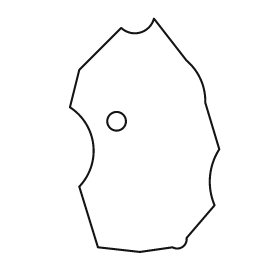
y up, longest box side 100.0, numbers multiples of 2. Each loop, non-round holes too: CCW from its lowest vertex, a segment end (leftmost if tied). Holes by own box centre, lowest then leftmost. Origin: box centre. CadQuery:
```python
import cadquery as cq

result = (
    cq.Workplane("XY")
    .moveTo(-2.0, -50.0)
    .lineTo(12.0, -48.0)
    .threePointArc((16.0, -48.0), (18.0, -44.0))
    .lineTo(30.0, -30.0)
    .threePointArc((28.0, -18.0), (32.0, -6.0))
    .lineTo(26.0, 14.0)
    .threePointArc((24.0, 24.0), (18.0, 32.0))
    .lineTo(4.0, 50.0)
    .threePointArc((-2.0, 44.0), (-10.0, 46.0))
    .lineTo(-28.0, 28.0)
    .lineTo(-32.0, 12.0)
    .threePointArc((-22.0, -4.0), (-28.0, -22.0))
    .lineTo(-20.0, -48.0)
    .close()
    .moveTo(-12.0, 6.0)
    .circle(4.0)
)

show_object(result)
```